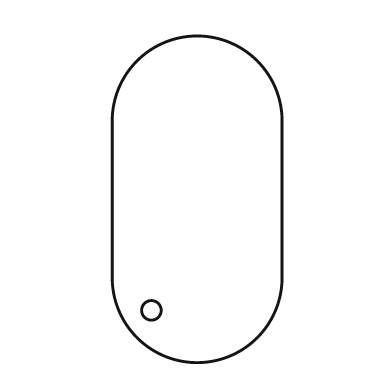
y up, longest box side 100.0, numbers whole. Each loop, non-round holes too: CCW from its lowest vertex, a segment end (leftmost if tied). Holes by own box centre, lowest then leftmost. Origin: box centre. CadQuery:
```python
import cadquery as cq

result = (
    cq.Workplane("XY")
    .moveTo(-26.0, -24.0)
    .threePointArc((0.0, -50.0), (26.0, -24.0))
    .lineTo(26.0, 24.0)
    .threePointArc((0.0, 50.0), (-26.0, 24.0))
    .close()
    .moveTo(-14.0, -34.0)
    .circle(3.0)
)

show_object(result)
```